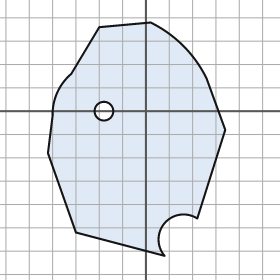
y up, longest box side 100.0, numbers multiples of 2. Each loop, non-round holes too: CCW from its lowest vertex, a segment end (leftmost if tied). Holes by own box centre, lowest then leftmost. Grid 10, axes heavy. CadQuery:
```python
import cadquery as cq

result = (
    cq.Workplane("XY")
    .moveTo(8.0, -62.0)
    .threePointArc((8.0, -48.0), (22.0, -46.0))
    .lineTo(34.0, -8.0)
    .lineTo(26.0, 14.0)
    .threePointArc((16.0, 28.0), (2.0, 38.0))
    .lineTo(-20.0, 36.0)
    .lineTo(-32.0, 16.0)
    .threePointArc((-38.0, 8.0), (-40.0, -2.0))
    .lineTo(-42.0, -18.0)
    .lineTo(-30.0, -52.0)
    .close()
    .moveTo(-18.0, 0.0)
    .circle(4.0)
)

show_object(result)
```